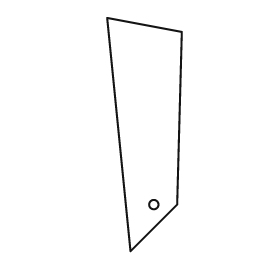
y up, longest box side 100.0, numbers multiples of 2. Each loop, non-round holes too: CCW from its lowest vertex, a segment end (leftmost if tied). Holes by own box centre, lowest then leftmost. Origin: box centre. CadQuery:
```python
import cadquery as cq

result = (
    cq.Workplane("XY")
    .moveTo(-6.0, -50.0)
    .lineTo(14.0, -30.0)
    .lineTo(16.0, 44.0)
    .lineTo(-16.0, 50.0)
    .close()
    .moveTo(4.0, -30.0)
    .circle(2.0)
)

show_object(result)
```